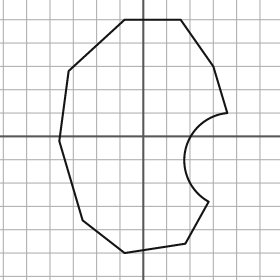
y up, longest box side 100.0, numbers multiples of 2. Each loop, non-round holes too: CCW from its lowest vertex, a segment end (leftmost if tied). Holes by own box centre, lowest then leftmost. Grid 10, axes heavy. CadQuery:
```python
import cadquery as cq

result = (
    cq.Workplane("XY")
    .moveTo(-8.0, -50.0)
    .lineTo(18.0, -46.0)
    .lineTo(28.0, -28.0)
    .threePointArc((18.0, -6.0), (36.0, 10.0))
    .lineTo(30.0, 30.0)
    .lineTo(16.0, 50.0)
    .lineTo(-8.0, 50.0)
    .lineTo(-32.0, 28.0)
    .lineTo(-36.0, -2.0)
    .lineTo(-26.0, -36.0)
    .close()
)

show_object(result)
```